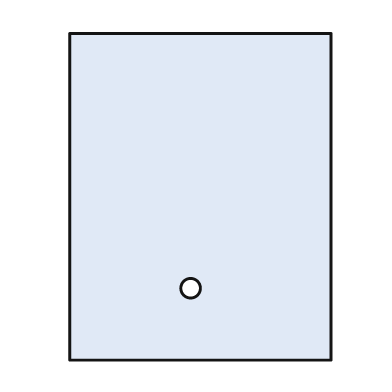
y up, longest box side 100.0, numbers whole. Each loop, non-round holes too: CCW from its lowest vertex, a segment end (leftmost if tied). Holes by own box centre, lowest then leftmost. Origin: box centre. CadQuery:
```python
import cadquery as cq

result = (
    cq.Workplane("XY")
    .moveTo(-40.0, -50.0)
    .lineTo(40.0, -50.0)
    .lineTo(40.0, 50.0)
    .lineTo(-40.0, 50.0)
    .close()
    .moveTo(-3.0, -28.0)
    .circle(3.0)
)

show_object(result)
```